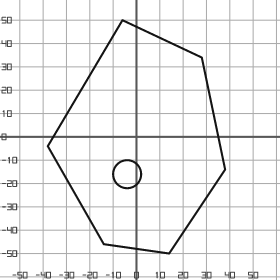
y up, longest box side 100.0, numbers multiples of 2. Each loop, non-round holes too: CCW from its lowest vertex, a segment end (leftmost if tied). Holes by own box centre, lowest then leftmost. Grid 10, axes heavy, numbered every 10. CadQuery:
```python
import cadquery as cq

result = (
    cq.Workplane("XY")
    .moveTo(14.0, -50.0)
    .lineTo(38.0, -14.0)
    .lineTo(28.0, 34.0)
    .lineTo(-6.0, 50.0)
    .lineTo(-38.0, -4.0)
    .lineTo(-14.0, -46.0)
    .close()
    .moveTo(-4.0, -16.0)
    .circle(6.0)
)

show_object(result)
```